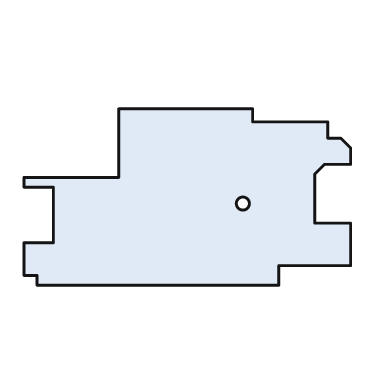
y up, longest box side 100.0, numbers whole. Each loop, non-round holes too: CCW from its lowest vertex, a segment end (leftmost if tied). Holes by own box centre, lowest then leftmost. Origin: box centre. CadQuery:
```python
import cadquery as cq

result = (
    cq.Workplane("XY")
    .moveTo(-46.0, -27.0)
    .lineTo(28.0, -27.0)
    .lineTo(28.0, -21.0)
    .lineTo(50.0, -21.0)
    .lineTo(50.0, -8.0)
    .lineTo(39.0, -8.0)
    .lineTo(39.0, 7.0)
    .lineTo(42.0, 10.0)
    .lineTo(50.0, 10.0)
    .lineTo(50.0, 15.0)
    .lineTo(47.0, 18.0)
    .lineTo(43.0, 18.0)
    .lineTo(43.0, 23.0)
    .lineTo(20.0, 23.0)
    .lineTo(20.0, 27.0)
    .lineTo(-21.0, 27.0)
    .lineTo(-21.0, 6.0)
    .lineTo(-50.0, 6.0)
    .lineTo(-50.0, 3.0)
    .lineTo(-41.0, 3.0)
    .lineTo(-41.0, -14.0)
    .lineTo(-50.0, -14.0)
    .lineTo(-50.0, -24.0)
    .lineTo(-46.0, -24.0)
    .close()
    .moveTo(17.0, -2.0)
    .circle(2.0)
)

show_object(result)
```